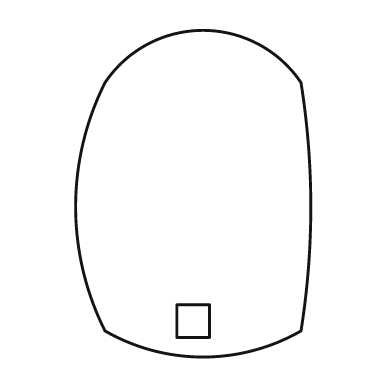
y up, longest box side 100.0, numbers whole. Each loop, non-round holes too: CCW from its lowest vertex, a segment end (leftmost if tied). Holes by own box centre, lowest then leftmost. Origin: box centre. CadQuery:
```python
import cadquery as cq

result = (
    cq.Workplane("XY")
    .moveTo(-27.0, -42.0)
    .threePointArc((3.0, -50.0), (33.0, -42.0))
    .threePointArc((36.0, -4.0), (33.0, 34.0))
    .threePointArc((3.0, 50.0), (-27.0, 34.0))
    .threePointArc((-36.0, -4.0), (-27.0, -42.0))
    .close()
    .moveTo(-5.0, -44.0)
    .lineTo(5.0, -44.0)
    .lineTo(5.0, -34.0)
    .lineTo(-5.0, -34.0)
    .close()
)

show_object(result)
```